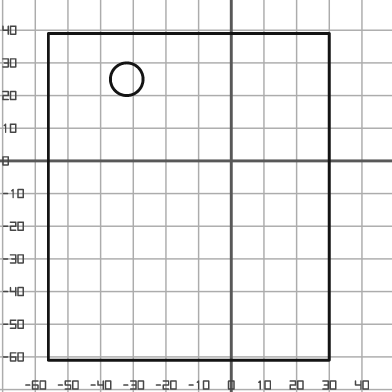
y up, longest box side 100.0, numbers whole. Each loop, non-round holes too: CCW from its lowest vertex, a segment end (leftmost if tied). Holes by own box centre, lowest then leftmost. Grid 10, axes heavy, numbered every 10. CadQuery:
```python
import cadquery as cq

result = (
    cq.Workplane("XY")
    .moveTo(-56.0, -61.0)
    .lineTo(30.0, -61.0)
    .lineTo(30.0, 39.0)
    .lineTo(-56.0, 39.0)
    .close()
    .moveTo(-32.0, 25.0)
    .circle(5.0)
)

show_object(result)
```